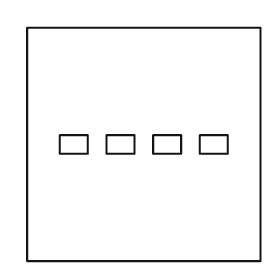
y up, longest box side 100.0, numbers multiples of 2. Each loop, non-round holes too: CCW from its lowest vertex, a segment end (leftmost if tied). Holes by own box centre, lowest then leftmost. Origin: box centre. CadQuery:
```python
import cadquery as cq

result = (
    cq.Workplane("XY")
    .moveTo(-50.0, -50.0)
    .lineTo(50.0, -50.0)
    .lineTo(50.0, 50.0)
    .lineTo(-50.0, 50.0)
    .close()
    .moveTo(-36.0, -4.0)
    .lineTo(-24.0, -4.0)
    .lineTo(-24.0, 4.0)
    .lineTo(-36.0, 4.0)
    .close()
    .moveTo(-16.0, -4.0)
    .lineTo(-4.0, -4.0)
    .lineTo(-4.0, 4.0)
    .lineTo(-16.0, 4.0)
    .close()
    .moveTo(4.0, -4.0)
    .lineTo(16.0, -4.0)
    .lineTo(16.0, 4.0)
    .lineTo(4.0, 4.0)
    .close()
    .moveTo(24.0, -4.0)
    .lineTo(36.0, -4.0)
    .lineTo(36.0, 4.0)
    .lineTo(24.0, 4.0)
    .close()
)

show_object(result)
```